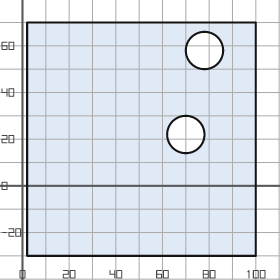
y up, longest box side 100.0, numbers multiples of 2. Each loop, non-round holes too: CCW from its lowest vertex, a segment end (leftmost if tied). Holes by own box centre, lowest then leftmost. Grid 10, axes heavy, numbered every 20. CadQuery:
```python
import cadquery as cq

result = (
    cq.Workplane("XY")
    .moveTo(2.0, -30.0)
    .lineTo(100.0, -30.0)
    .lineTo(100.0, 70.0)
    .lineTo(2.0, 70.0)
    .close()
    .moveTo(70.0, 22.0)
    .circle(8.0)
    .moveTo(78.0, 58.0)
    .circle(8.0)
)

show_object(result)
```